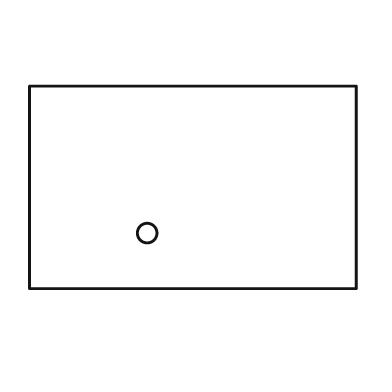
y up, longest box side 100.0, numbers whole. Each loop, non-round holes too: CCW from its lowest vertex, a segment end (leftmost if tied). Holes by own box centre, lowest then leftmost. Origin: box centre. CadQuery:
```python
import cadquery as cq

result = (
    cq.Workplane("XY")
    .moveTo(-50.0, -31.0)
    .lineTo(50.0, -31.0)
    .lineTo(50.0, 31.0)
    .lineTo(-50.0, 31.0)
    .close()
    .moveTo(-14.0, -14.0)
    .circle(3.0)
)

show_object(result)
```